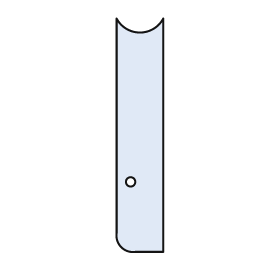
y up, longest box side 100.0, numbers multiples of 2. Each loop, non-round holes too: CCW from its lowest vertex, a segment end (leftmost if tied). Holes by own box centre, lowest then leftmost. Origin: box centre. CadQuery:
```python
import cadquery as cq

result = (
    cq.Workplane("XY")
    .moveTo(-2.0, -50.0)
    .lineTo(10.0, -50.0)
    .lineTo(10.0, 50.0)
    .threePointArc((0.0, 44.0), (-10.0, 50.0))
    .lineTo(-10.0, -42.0)
    .threePointArc((-8.0, -48.0), (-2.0, -50.0))
    .close()
    .moveTo(-4.0, -20.0)
    .circle(2.0)
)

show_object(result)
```